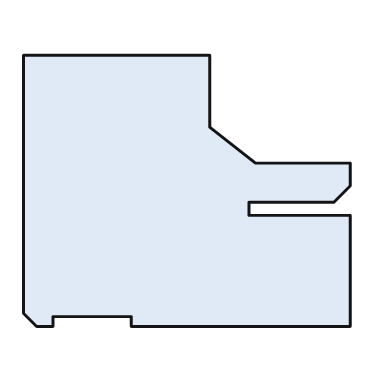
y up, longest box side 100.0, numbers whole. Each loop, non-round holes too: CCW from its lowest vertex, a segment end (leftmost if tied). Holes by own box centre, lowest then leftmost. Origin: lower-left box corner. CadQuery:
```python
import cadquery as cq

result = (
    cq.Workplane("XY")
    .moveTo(4.0, 0.0)
    .lineTo(9.0, 0.0)
    .lineTo(9.0, 3.0)
    .lineTo(33.0, 3.0)
    .lineTo(33.0, 0.0)
    .lineTo(100.0, 0.0)
    .lineTo(100.0, 34.0)
    .lineTo(69.0, 34.0)
    .lineTo(69.0, 38.0)
    .lineTo(95.0, 38.0)
    .lineTo(100.0, 43.0)
    .lineTo(100.0, 50.0)
    .lineTo(71.0, 50.0)
    .lineTo(57.0, 61.0)
    .lineTo(57.0, 83.0)
    .lineTo(0.0, 83.0)
    .lineTo(0.0, 4.0)
    .close()
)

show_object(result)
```